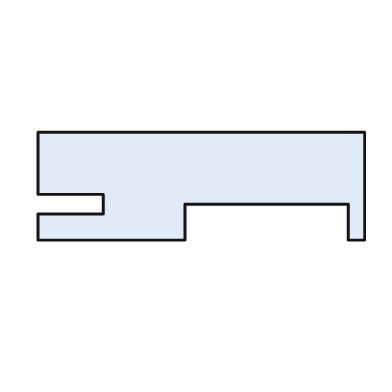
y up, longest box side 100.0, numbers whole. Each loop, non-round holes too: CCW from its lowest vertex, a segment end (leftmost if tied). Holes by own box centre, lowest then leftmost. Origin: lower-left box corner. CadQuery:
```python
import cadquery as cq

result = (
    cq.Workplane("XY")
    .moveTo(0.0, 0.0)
    .lineTo(45.0, 0.0)
    .lineTo(45.0, 11.0)
    .lineTo(95.0, 11.0)
    .lineTo(95.0, 0.0)
    .lineTo(100.0, 0.0)
    .lineTo(100.0, 33.0)
    .lineTo(0.0, 33.0)
    .lineTo(0.0, 14.0)
    .lineTo(20.0, 14.0)
    .lineTo(20.0, 8.0)
    .lineTo(0.0, 8.0)
    .close()
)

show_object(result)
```